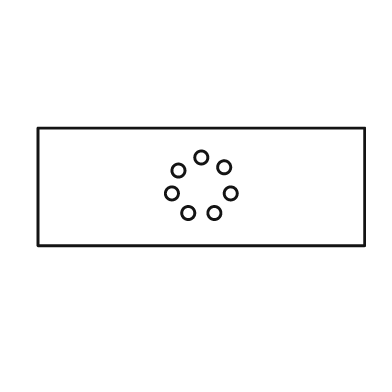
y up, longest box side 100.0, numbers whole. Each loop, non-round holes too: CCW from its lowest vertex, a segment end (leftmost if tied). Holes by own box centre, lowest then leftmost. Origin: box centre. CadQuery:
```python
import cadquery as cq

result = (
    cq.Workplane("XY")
    .moveTo(-50.0, -18.0)
    .lineTo(50.0, -18.0)
    .lineTo(50.0, 18.0)
    .lineTo(-50.0, 18.0)
    .close()
    .moveTo(-4.0, -8.0)
    .circle(2.0)
    .moveTo(4.0, -8.0)
    .circle(2.0)
    .moveTo(-9.0, -2.0)
    .circle(2.0)
    .moveTo(9.0, -2.0)
    .circle(2.0)
    .moveTo(-7.0, 5.0)
    .circle(2.0)
    .moveTo(7.0, 6.0)
    .circle(2.0)
    .moveTo(0.0, 9.0)
    .circle(2.0)
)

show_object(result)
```